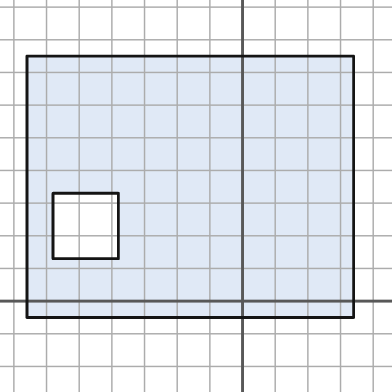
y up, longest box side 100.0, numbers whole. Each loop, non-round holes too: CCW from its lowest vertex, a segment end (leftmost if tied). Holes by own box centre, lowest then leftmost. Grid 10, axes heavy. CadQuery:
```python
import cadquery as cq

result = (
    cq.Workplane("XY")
    .moveTo(-66.0, -5.0)
    .lineTo(34.0, -5.0)
    .lineTo(34.0, 75.0)
    .lineTo(-66.0, 75.0)
    .close()
    .moveTo(-58.0, 13.0)
    .lineTo(-38.0, 13.0)
    .lineTo(-38.0, 33.0)
    .lineTo(-58.0, 33.0)
    .close()
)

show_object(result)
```